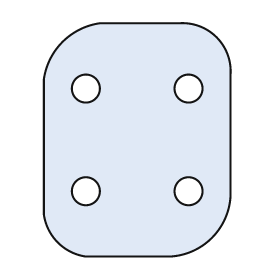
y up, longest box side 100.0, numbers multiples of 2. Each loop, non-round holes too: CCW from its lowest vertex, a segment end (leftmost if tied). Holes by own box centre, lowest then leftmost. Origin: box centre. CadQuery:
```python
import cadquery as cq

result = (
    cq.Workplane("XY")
    .moveTo(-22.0, -50.0)
    .lineTo(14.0, -50.0)
    .threePointArc((32.0, -42.0), (40.0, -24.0))
    .lineTo(40.0, 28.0)
    .threePointArc((34.0, 44.0), (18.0, 50.0))
    .lineTo(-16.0, 50.0)
    .threePointArc((-32.0, 42.0), (-40.0, 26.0))
    .lineTo(-40.0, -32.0)
    .threePointArc((-34.0, -44.0), (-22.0, -50.0))
    .close()
    .moveTo(-22.0, -22.0)
    .circle(6.0)
    .moveTo(22.0, -22.0)
    .circle(6.0)
    .moveTo(-22.0, 22.0)
    .circle(6.0)
    .moveTo(22.0, 22.0)
    .circle(6.0)
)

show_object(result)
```